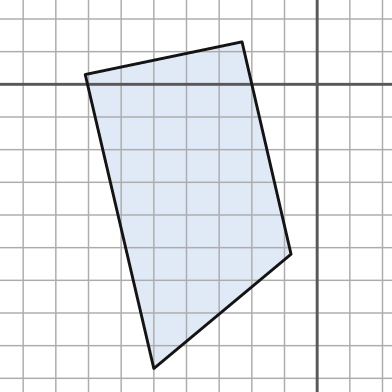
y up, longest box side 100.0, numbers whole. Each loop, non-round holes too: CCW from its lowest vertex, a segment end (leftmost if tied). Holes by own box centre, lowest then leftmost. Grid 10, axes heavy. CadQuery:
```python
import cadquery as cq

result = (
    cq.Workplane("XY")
    .moveTo(-50.0, -87.0)
    .lineTo(-8.0, -52.0)
    .lineTo(-23.0, 13.0)
    .lineTo(-71.0, 3.0)
    .close()
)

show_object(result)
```